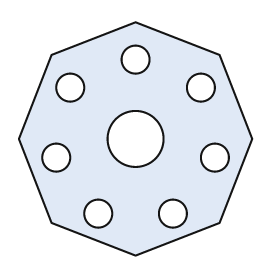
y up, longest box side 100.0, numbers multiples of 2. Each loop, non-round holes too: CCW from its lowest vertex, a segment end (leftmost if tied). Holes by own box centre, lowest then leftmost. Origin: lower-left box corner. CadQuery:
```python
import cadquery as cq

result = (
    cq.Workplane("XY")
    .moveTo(50.0, 0.0)
    .lineTo(86.0, 14.0)
    .lineTo(100.0, 50.0)
    .lineTo(86.0, 86.0)
    .lineTo(50.0, 100.0)
    .lineTo(14.0, 86.0)
    .lineTo(0.0, 50.0)
    .lineTo(14.0, 14.0)
    .close()
    .moveTo(34.0, 18.0)
    .circle(6.0)
    .moveTo(66.0, 18.0)
    .circle(6.0)
    .moveTo(16.0, 42.0)
    .circle(6.0)
    .moveTo(84.0, 42.0)
    .circle(6.0)
    .moveTo(50.0, 50.0)
    .circle(12.0)
    .moveTo(22.0, 72.0)
    .circle(6.0)
    .moveTo(78.0, 72.0)
    .circle(6.0)
    .moveTo(50.0, 84.0)
    .circle(6.0)
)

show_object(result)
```